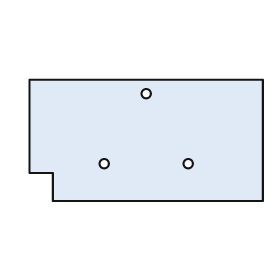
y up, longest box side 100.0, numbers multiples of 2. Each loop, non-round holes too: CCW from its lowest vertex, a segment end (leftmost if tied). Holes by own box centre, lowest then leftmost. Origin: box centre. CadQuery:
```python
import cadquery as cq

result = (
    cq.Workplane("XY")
    .moveTo(-40.0, -26.0)
    .lineTo(50.0, -26.0)
    .lineTo(50.0, 26.0)
    .lineTo(-50.0, 26.0)
    .lineTo(-50.0, -14.0)
    .lineTo(-40.0, -14.0)
    .close()
    .moveTo(-18.0, -10.0)
    .circle(2.0)
    .moveTo(18.0, -10.0)
    .circle(2.0)
    .moveTo(0.0, 20.0)
    .circle(2.0)
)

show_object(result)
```